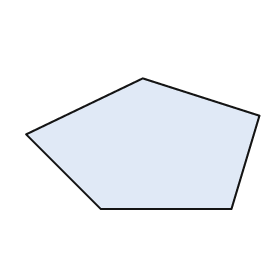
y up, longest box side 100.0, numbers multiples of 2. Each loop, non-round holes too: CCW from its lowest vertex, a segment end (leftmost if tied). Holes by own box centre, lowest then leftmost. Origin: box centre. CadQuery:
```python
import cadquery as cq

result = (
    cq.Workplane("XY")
    .moveTo(-18.0, -28.0)
    .lineTo(38.0, -28.0)
    .lineTo(50.0, 12.0)
    .lineTo(0.0, 28.0)
    .lineTo(-50.0, 4.0)
    .close()
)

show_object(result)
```